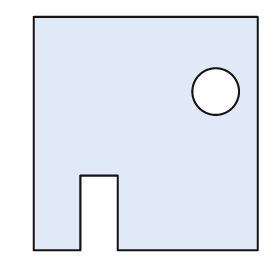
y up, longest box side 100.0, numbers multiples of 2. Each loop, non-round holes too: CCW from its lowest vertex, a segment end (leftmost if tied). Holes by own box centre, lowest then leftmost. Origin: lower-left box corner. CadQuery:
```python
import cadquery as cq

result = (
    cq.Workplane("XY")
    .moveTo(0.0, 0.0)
    .lineTo(20.0, 0.0)
    .lineTo(20.0, 32.0)
    .lineTo(36.0, 32.0)
    .lineTo(36.0, 0.0)
    .lineTo(96.0, 0.0)
    .lineTo(96.0, 100.0)
    .lineTo(0.0, 100.0)
    .close()
    .moveTo(78.0, 68.0)
    .circle(10.0)
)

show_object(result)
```